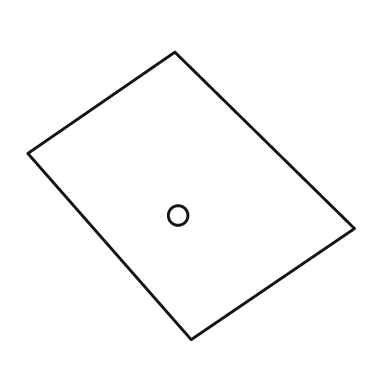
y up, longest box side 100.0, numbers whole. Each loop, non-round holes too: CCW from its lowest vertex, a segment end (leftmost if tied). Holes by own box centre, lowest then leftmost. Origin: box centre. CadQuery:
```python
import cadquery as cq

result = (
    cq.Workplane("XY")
    .moveTo(0.0, -44.0)
    .lineTo(50.0, -10.0)
    .lineTo(-5.0, 44.0)
    .lineTo(-50.0, 13.0)
    .close()
    .moveTo(-4.0, -6.0)
    .circle(3.0)
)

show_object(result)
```